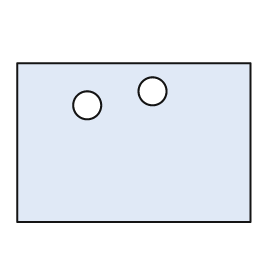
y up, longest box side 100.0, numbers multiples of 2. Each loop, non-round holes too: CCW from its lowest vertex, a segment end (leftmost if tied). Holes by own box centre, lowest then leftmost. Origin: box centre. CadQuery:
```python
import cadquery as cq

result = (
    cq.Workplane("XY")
    .moveTo(-50.0, -34.0)
    .lineTo(50.0, -34.0)
    .lineTo(50.0, 34.0)
    .lineTo(-50.0, 34.0)
    .close()
    .moveTo(-20.0, 16.0)
    .circle(6.0)
    .moveTo(8.0, 22.0)
    .circle(6.0)
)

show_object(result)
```